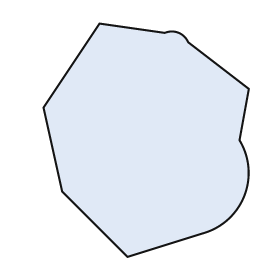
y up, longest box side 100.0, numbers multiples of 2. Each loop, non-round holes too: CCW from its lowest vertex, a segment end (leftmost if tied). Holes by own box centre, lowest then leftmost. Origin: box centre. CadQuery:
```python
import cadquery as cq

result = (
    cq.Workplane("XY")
    .moveTo(-8.0, -50.0)
    .lineTo(24.0, -40.0)
    .threePointArc((42.0, -24.0), (40.0, 0.0))
    .lineTo(44.0, 22.0)
    .lineTo(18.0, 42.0)
    .threePointArc((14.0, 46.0), (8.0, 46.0))
    .lineTo(-20.0, 50.0)
    .lineTo(-44.0, 14.0)
    .lineTo(-36.0, -22.0)
    .close()
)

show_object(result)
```